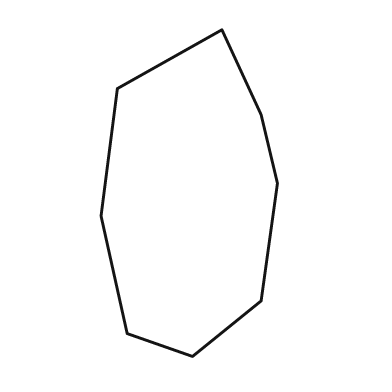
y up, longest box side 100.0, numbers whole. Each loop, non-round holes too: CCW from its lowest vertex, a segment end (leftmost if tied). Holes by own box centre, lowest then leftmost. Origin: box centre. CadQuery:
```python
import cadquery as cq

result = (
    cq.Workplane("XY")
    .moveTo(1.0, -50.0)
    .lineTo(22.0, -33.0)
    .lineTo(27.0, 3.0)
    .lineTo(22.0, 24.0)
    .lineTo(10.0, 50.0)
    .lineTo(-22.0, 32.0)
    .lineTo(-27.0, -7.0)
    .lineTo(-19.0, -43.0)
    .close()
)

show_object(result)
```